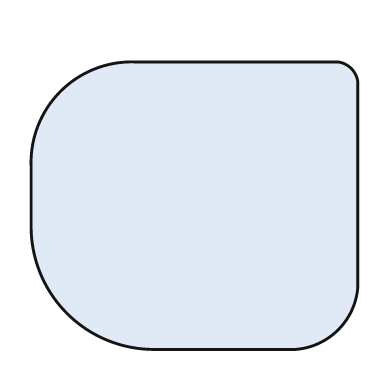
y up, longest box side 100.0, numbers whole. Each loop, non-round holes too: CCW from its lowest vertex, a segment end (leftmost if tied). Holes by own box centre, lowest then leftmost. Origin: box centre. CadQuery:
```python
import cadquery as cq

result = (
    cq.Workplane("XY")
    .moveTo(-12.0, -44.0)
    .lineTo(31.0, -44.0)
    .threePointArc((44.0, -38.0), (50.0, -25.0))
    .lineTo(50.0, 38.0)
    .threePointArc((48.0, 42.0), (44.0, 44.0))
    .lineTo(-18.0, 44.0)
    .threePointArc((-41.0, 35.0), (-50.0, 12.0))
    .lineTo(-50.0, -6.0)
    .threePointArc((-39.0, -33.0), (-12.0, -44.0))
    .close()
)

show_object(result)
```